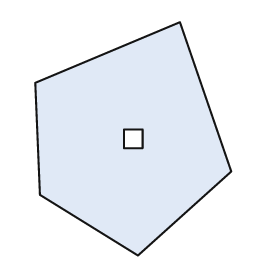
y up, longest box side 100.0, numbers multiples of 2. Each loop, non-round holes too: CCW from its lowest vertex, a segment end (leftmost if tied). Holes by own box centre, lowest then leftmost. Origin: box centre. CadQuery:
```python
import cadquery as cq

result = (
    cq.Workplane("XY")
    .moveTo(2.0, -50.0)
    .lineTo(42.0, -14.0)
    .lineTo(20.0, 50.0)
    .lineTo(-42.0, 24.0)
    .lineTo(-40.0, -24.0)
    .close()
    .moveTo(-4.0, -4.0)
    .lineTo(4.0, -4.0)
    .lineTo(4.0, 4.0)
    .lineTo(-4.0, 4.0)
    .close()
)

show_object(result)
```